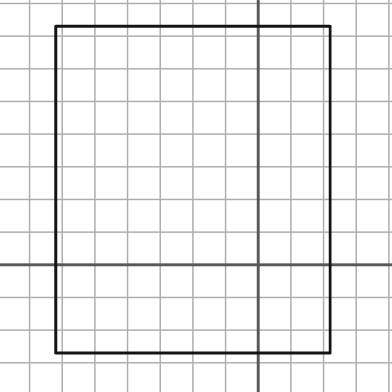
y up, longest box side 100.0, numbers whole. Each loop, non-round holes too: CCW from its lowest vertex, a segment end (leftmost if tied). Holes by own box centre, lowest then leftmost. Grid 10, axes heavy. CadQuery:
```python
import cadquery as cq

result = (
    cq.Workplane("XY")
    .moveTo(-62.0, -27.0)
    .lineTo(22.0, -27.0)
    .lineTo(22.0, 73.0)
    .lineTo(-62.0, 73.0)
    .close()
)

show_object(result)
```